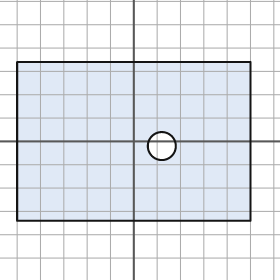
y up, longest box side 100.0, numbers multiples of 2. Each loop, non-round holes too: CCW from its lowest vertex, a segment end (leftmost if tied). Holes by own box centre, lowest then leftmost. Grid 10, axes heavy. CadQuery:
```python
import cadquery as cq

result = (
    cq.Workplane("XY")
    .moveTo(-50.0, -34.0)
    .lineTo(50.0, -34.0)
    .lineTo(50.0, 34.0)
    .lineTo(-50.0, 34.0)
    .close()
    .moveTo(12.0, -2.0)
    .circle(6.0)
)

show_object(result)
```